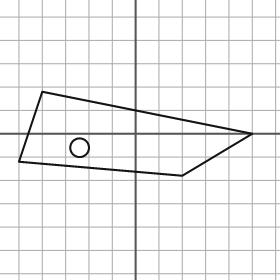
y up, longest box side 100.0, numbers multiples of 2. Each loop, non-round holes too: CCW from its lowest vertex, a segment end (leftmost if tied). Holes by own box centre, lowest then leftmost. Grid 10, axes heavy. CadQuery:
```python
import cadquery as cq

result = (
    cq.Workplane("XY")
    .moveTo(20.0, -18.0)
    .lineTo(50.0, 0.0)
    .lineTo(-40.0, 18.0)
    .lineTo(-50.0, -12.0)
    .close()
    .moveTo(-24.0, -6.0)
    .circle(4.0)
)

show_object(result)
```